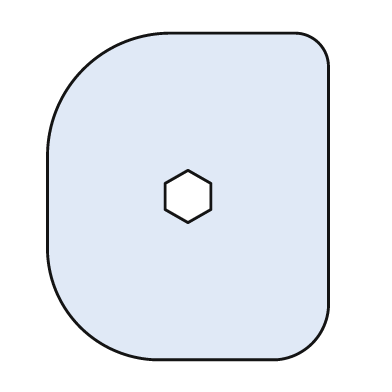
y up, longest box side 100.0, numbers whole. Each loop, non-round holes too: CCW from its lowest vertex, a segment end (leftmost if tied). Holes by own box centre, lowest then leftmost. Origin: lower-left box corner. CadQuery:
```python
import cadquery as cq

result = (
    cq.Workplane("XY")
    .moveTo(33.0, 0.0)
    .lineTo(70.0, 0.0)
    .threePointArc((81.0, 5.0), (86.0, 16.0))
    .lineTo(86.0, 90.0)
    .threePointArc((83.0, 97.0), (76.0, 100.0))
    .lineTo(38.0, 100.0)
    .threePointArc((11.0, 89.0), (0.0, 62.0))
    .lineTo(0.0, 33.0)
    .threePointArc((10.0, 10.0), (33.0, 0.0))
    .close()
    .moveTo(43.0, 42.0)
    .lineTo(50.0, 46.0)
    .lineTo(50.0, 54.0)
    .lineTo(43.0, 58.0)
    .lineTo(36.0, 54.0)
    .lineTo(36.0, 46.0)
    .close()
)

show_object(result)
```